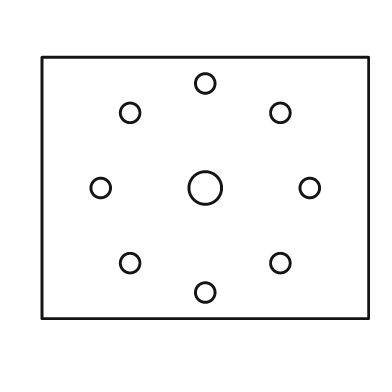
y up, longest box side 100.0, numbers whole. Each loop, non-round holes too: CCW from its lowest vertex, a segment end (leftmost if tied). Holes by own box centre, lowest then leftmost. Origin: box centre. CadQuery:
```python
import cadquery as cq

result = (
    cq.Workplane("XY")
    .moveTo(-50.0, -40.0)
    .lineTo(50.0, -40.0)
    .lineTo(50.0, 40.0)
    .lineTo(-50.0, 40.0)
    .close()
    .moveTo(0.0, -32.0)
    .circle(3.0)
    .moveTo(-23.0, -23.0)
    .circle(3.0)
    .moveTo(23.0, -23.0)
    .circle(3.0)
    .moveTo(-32.0, 0.0)
    .circle(3.0)
    .moveTo(0.0, 0.0)
    .circle(5.0)
    .moveTo(32.0, 0.0)
    .circle(3.0)
    .moveTo(-23.0, 23.0)
    .circle(3.0)
    .moveTo(23.0, 23.0)
    .circle(3.0)
    .moveTo(0.0, 32.0)
    .circle(3.0)
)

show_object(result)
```